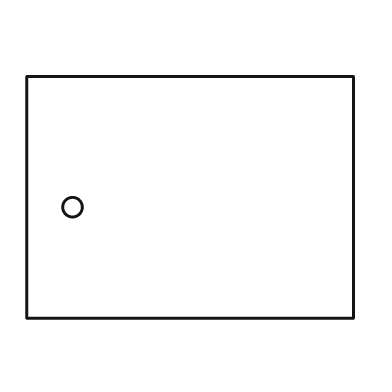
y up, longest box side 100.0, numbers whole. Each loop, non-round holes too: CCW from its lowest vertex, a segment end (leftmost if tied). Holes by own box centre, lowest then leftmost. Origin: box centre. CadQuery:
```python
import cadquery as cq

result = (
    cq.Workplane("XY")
    .moveTo(-50.0, -37.0)
    .lineTo(50.0, -37.0)
    .lineTo(50.0, 37.0)
    .lineTo(-50.0, 37.0)
    .close()
    .moveTo(-36.0, -3.0)
    .circle(3.0)
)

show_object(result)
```